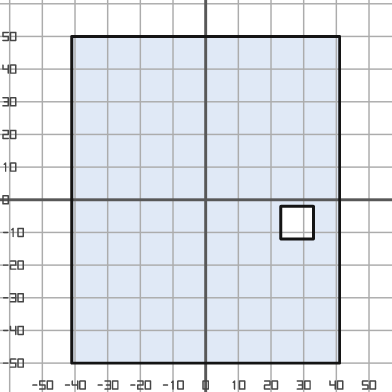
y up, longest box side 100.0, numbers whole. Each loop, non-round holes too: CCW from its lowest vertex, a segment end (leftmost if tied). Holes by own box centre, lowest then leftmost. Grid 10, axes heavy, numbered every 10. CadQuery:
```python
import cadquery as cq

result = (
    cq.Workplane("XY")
    .moveTo(-41.0, -50.0)
    .lineTo(41.0, -50.0)
    .lineTo(41.0, 50.0)
    .lineTo(-41.0, 50.0)
    .close()
    .moveTo(23.0, -12.0)
    .lineTo(33.0, -12.0)
    .lineTo(33.0, -2.0)
    .lineTo(23.0, -2.0)
    .close()
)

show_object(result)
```